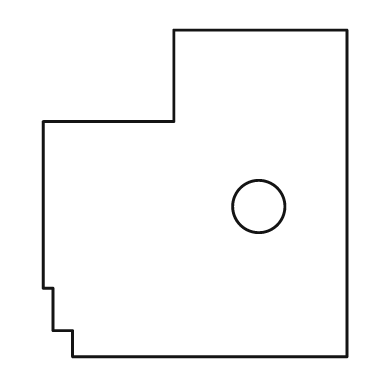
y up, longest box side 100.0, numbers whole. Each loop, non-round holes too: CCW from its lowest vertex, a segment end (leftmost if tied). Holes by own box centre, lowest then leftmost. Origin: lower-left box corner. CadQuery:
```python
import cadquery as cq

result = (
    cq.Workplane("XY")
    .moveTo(9.0, 0.0)
    .lineTo(93.0, 0.0)
    .lineTo(93.0, 100.0)
    .lineTo(40.0, 100.0)
    .lineTo(40.0, 72.0)
    .lineTo(0.0, 72.0)
    .lineTo(0.0, 21.0)
    .lineTo(3.0, 21.0)
    .lineTo(3.0, 8.0)
    .lineTo(9.0, 8.0)
    .close()
    .moveTo(66.0, 46.0)
    .circle(8.0)
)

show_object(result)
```